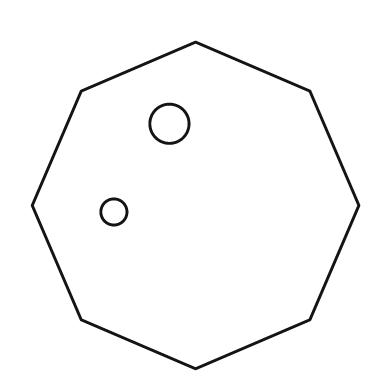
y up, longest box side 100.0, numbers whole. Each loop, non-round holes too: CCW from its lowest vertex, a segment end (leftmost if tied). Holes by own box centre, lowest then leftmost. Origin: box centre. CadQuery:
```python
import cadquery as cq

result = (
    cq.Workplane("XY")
    .moveTo(0.0, -50.0)
    .lineTo(35.0, -35.0)
    .lineTo(50.0, 0.0)
    .lineTo(35.0, 35.0)
    .lineTo(0.0, 50.0)
    .lineTo(-35.0, 35.0)
    .lineTo(-50.0, 0.0)
    .lineTo(-35.0, -35.0)
    .close()
    .moveTo(-25.0, -2.0)
    .circle(4.0)
    .moveTo(-8.0, 25.0)
    .circle(6.0)
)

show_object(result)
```